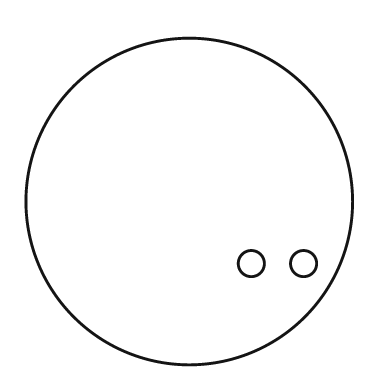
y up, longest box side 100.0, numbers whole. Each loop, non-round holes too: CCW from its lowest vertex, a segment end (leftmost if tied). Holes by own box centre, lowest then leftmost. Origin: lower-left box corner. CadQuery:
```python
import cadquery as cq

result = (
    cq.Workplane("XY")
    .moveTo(50.0, 50.0)
    .circle(50.0)
    .moveTo(69.0, 31.0)
    .circle(4.0)
    .moveTo(85.0, 31.0)
    .circle(4.0)
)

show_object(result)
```